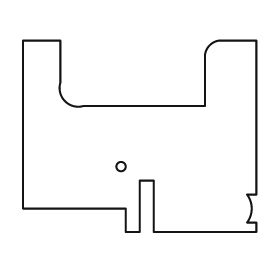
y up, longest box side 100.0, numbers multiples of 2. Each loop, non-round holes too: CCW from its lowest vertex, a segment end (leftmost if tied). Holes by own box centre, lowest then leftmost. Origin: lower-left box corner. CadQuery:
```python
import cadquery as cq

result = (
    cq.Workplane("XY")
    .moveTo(44.0, 0.0)
    .lineTo(50.0, 0.0)
    .lineTo(50.0, 22.0)
    .lineTo(56.0, 22.0)
    .lineTo(56.0, 0.0)
    .lineTo(100.0, 0.0)
    .lineTo(100.0, 4.0)
    .lineTo(96.0, 4.0)
    .threePointArc((98.0, 10.0), (96.0, 16.0))
    .lineTo(100.0, 16.0)
    .lineTo(100.0, 82.0)
    .lineTo(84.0, 82.0)
    .threePointArc((80.0, 80.0), (78.0, 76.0))
    .lineTo(78.0, 54.0)
    .lineTo(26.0, 54.0)
    .threePointArc((18.0, 56.0), (16.0, 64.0))
    .lineTo(16.0, 82.0)
    .lineTo(0.0, 82.0)
    .lineTo(0.0, 10.0)
    .lineTo(44.0, 10.0)
    .close()
    .moveTo(42.0, 28.0)
    .circle(2.0)
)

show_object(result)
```